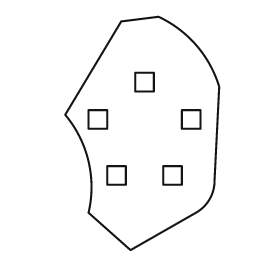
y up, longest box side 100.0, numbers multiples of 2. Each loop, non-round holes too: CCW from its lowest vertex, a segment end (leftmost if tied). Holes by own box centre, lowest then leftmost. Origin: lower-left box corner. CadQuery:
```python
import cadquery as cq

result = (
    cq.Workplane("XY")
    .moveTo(28.0, 0.0)
    .lineTo(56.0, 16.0)
    .threePointArc((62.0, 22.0), (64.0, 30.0))
    .lineTo(66.0, 70.0)
    .threePointArc((56.0, 88.0), (40.0, 100.0))
    .lineTo(24.0, 98.0)
    .lineTo(0.0, 58.0)
    .threePointArc((10.0, 38.0), (10.0, 16.0))
    .close()
    .moveTo(18.0, 28.0)
    .lineTo(26.0, 28.0)
    .lineTo(26.0, 36.0)
    .lineTo(18.0, 36.0)
    .close()
    .moveTo(42.0, 28.0)
    .lineTo(50.0, 28.0)
    .lineTo(50.0, 36.0)
    .lineTo(42.0, 36.0)
    .close()
    .moveTo(10.0, 52.0)
    .lineTo(18.0, 52.0)
    .lineTo(18.0, 60.0)
    .lineTo(10.0, 60.0)
    .close()
    .moveTo(50.0, 52.0)
    .lineTo(58.0, 52.0)
    .lineTo(58.0, 60.0)
    .lineTo(50.0, 60.0)
    .close()
    .moveTo(30.0, 68.0)
    .lineTo(38.0, 68.0)
    .lineTo(38.0, 76.0)
    .lineTo(30.0, 76.0)
    .close()
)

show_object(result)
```